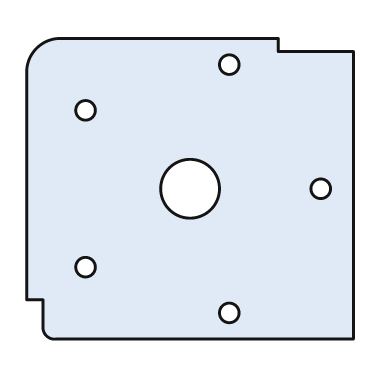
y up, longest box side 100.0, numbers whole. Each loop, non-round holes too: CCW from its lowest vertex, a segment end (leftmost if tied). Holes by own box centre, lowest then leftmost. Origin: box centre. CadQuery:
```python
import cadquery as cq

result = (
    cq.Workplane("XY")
    .moveTo(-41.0, -46.0)
    .lineTo(50.0, -46.0)
    .lineTo(50.0, 42.0)
    .lineTo(27.0, 42.0)
    .lineTo(27.0, 46.0)
    .lineTo(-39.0, 46.0)
    .threePointArc((-47.0, 43.0), (-50.0, 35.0))
    .lineTo(-50.0, -34.0)
    .lineTo(-45.0, -34.0)
    .lineTo(-45.0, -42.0)
    .threePointArc((-44.0, -45.0), (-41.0, -46.0))
    .close()
    .moveTo(12.0, -38.0)
    .circle(3.0)
    .moveTo(-32.0, -24.0)
    .circle(3.0)
    .moveTo(0.0, 0.0)
    .circle(9.0)
    .moveTo(40.0, 0.0)
    .circle(3.0)
    .moveTo(-32.0, 24.0)
    .circle(3.0)
    .moveTo(12.0, 38.0)
    .circle(3.0)
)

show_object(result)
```